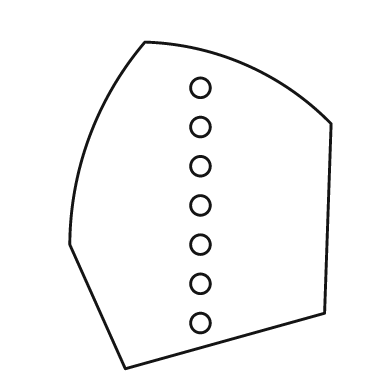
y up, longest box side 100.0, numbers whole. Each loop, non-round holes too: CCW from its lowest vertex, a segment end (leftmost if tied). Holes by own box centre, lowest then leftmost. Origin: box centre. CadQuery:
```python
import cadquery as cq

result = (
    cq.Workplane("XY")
    .moveTo(-23.0, -50.0)
    .lineTo(38.0, -33.0)
    .lineTo(40.0, 25.0)
    .threePointArc((14.0, 43.0), (-17.0, 50.0))
    .threePointArc((-34.0, 21.0), (-40.0, -12.0))
    .close()
    .moveTo(0.0, -36.0)
    .circle(3.0)
    .moveTo(0.0, -24.0)
    .circle(3.0)
    .moveTo(0.0, -12.0)
    .circle(3.0)
    .moveTo(0.0, 0.0)
    .circle(3.0)
    .moveTo(0.0, 12.0)
    .circle(3.0)
    .moveTo(0.0, 24.0)
    .circle(3.0)
    .moveTo(0.0, 36.0)
    .circle(3.0)
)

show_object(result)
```